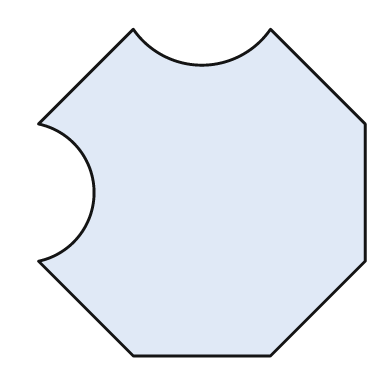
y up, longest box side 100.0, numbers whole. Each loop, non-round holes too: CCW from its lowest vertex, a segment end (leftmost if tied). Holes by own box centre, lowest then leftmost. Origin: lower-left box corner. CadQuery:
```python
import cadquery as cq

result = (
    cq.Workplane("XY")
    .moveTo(29.0, 0.0)
    .lineTo(71.0, 0.0)
    .lineTo(100.0, 29.0)
    .lineTo(100.0, 71.0)
    .lineTo(71.0, 100.0)
    .threePointArc((50.0, 89.0), (29.0, 100.0))
    .lineTo(0.0, 71.0)
    .threePointArc((17.0, 50.0), (0.0, 29.0))
    .close()
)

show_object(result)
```